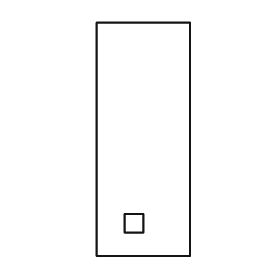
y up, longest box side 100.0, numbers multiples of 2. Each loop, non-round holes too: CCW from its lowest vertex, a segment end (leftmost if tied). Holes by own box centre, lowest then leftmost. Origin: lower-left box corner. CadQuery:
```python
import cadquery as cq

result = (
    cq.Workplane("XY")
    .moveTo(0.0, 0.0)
    .lineTo(40.0, 0.0)
    .lineTo(40.0, 100.0)
    .lineTo(0.0, 100.0)
    .close()
    .moveTo(12.0, 10.0)
    .lineTo(20.0, 10.0)
    .lineTo(20.0, 18.0)
    .lineTo(12.0, 18.0)
    .close()
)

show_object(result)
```